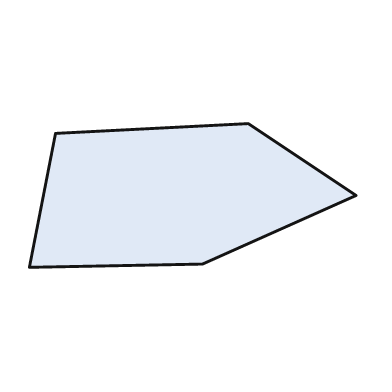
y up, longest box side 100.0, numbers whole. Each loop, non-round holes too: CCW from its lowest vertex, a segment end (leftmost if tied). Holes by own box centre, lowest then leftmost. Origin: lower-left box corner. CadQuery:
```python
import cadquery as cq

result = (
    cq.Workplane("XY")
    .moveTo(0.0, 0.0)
    .lineTo(53.0, 1.0)
    .lineTo(100.0, 22.0)
    .lineTo(67.0, 44.0)
    .lineTo(8.0, 41.0)
    .close()
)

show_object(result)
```